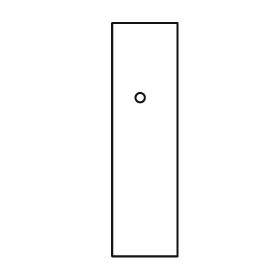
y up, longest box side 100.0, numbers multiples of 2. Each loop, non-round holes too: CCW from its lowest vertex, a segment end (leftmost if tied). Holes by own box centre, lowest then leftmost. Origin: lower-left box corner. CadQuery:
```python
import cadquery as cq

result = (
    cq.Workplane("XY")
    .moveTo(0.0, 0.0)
    .lineTo(28.0, 0.0)
    .lineTo(28.0, 100.0)
    .lineTo(0.0, 100.0)
    .close()
    .moveTo(12.0, 68.0)
    .circle(2.0)
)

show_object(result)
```